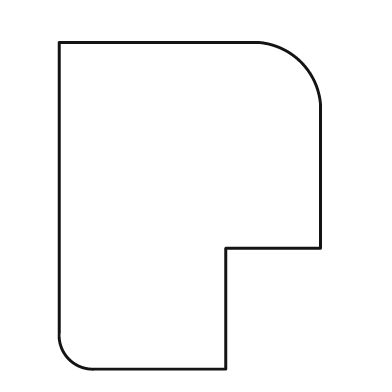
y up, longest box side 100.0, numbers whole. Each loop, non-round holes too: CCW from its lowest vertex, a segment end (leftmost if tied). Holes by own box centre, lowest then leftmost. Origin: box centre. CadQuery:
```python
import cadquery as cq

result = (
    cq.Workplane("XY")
    .moveTo(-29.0, -50.0)
    .lineTo(11.0, -50.0)
    .lineTo(11.0, -13.0)
    .lineTo(40.0, -13.0)
    .lineTo(40.0, 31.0)
    .threePointArc((34.0, 44.0), (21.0, 50.0))
    .lineTo(-40.0, 50.0)
    .lineTo(-40.0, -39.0)
    .threePointArc((-37.0, -47.0), (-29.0, -50.0))
    .close()
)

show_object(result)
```